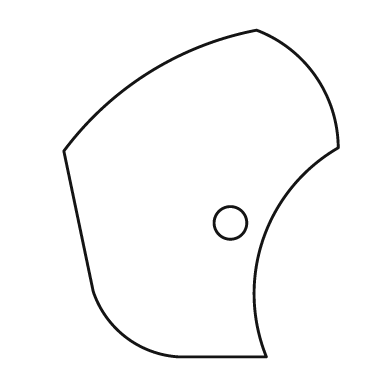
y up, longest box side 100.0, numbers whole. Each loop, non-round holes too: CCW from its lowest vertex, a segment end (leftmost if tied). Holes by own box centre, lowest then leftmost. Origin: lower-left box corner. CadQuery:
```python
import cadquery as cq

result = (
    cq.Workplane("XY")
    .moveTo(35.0, 0.0)
    .lineTo(62.0, 0.0)
    .threePointArc((61.0, 36.0), (84.0, 64.0))
    .threePointArc((77.0, 86.0), (59.0, 100.0))
    .threePointArc((26.0, 87.0), (0.0, 63.0))
    .lineTo(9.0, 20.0)
    .threePointArc((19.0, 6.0), (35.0, 0.0))
    .close()
    .moveTo(51.0, 41.0)
    .circle(5.0)
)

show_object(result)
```